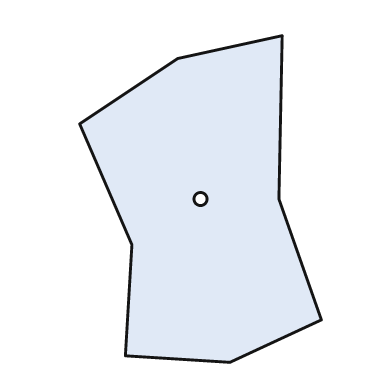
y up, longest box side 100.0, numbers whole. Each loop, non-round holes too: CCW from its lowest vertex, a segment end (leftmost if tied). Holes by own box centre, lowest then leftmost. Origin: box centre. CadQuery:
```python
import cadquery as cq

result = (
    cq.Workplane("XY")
    .moveTo(9.0, -50.0)
    .lineTo(37.0, -37.0)
    .lineTo(24.0, 0.0)
    .lineTo(25.0, 50.0)
    .lineTo(-7.0, 43.0)
    .lineTo(-37.0, 23.0)
    .lineTo(-21.0, -14.0)
    .lineTo(-23.0, -48.0)
    .close()
    .moveTo(0.0, 0.0)
    .circle(2.0)
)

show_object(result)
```